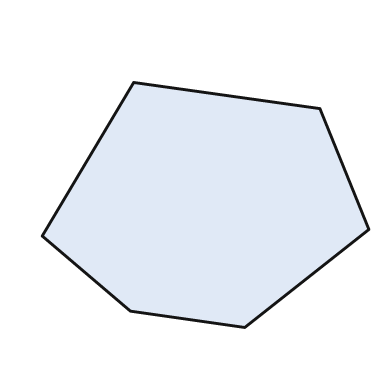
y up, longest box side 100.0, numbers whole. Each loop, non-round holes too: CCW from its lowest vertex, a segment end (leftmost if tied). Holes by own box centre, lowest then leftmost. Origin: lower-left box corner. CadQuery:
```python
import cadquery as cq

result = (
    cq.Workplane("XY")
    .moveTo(62.0, 0.0)
    .lineTo(100.0, 30.0)
    .lineTo(85.0, 67.0)
    .lineTo(28.0, 75.0)
    .lineTo(0.0, 28.0)
    .lineTo(27.0, 5.0)
    .close()
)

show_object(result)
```